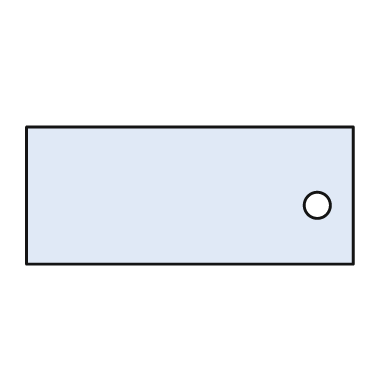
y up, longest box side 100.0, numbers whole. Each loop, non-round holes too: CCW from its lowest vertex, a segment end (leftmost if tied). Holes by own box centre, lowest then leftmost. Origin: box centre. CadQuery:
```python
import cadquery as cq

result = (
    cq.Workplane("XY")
    .moveTo(-50.0, -21.0)
    .lineTo(50.0, -21.0)
    .lineTo(50.0, 21.0)
    .lineTo(-50.0, 21.0)
    .close()
    .moveTo(39.0, -3.0)
    .circle(4.0)
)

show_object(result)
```